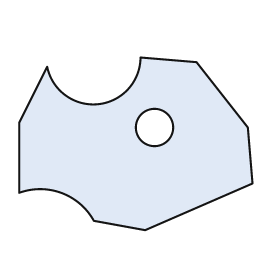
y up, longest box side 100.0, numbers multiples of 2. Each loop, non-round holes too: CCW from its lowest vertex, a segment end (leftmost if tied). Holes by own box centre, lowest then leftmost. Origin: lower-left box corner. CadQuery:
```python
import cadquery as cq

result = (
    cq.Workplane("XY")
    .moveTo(54.0, 0.0)
    .lineTo(100.0, 20.0)
    .lineTo(98.0, 44.0)
    .lineTo(76.0, 72.0)
    .lineTo(52.0, 74.0)
    .threePointArc((34.0, 54.0), (12.0, 70.0))
    .lineTo(0.0, 46.0)
    .lineTo(0.0, 16.0)
    .threePointArc((18.0, 16.0), (32.0, 4.0))
    .close()
    .moveTo(58.0, 44.0)
    .circle(8.0)
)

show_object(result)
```